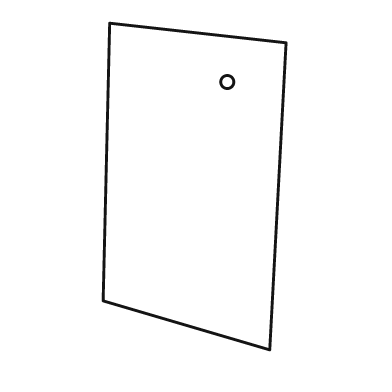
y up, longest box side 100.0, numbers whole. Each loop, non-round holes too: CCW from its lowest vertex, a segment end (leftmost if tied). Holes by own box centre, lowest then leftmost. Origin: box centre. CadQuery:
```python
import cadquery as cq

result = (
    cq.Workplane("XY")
    .moveTo(23.0, -50.0)
    .lineTo(28.0, 44.0)
    .lineTo(-26.0, 50.0)
    .lineTo(-28.0, -35.0)
    .close()
    .moveTo(10.0, 32.0)
    .circle(2.0)
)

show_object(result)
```